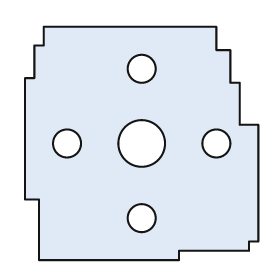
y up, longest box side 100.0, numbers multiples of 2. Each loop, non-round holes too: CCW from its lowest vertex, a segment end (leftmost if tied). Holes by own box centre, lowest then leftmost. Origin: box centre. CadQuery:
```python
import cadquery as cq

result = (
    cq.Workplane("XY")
    .moveTo(-44.0, -50.0)
    .lineTo(16.0, -50.0)
    .lineTo(16.0, -46.0)
    .lineTo(46.0, -46.0)
    .lineTo(46.0, -42.0)
    .lineTo(50.0, -42.0)
    .lineTo(50.0, 8.0)
    .lineTo(42.0, 8.0)
    .lineTo(42.0, 26.0)
    .lineTo(38.0, 26.0)
    .lineTo(38.0, 40.0)
    .lineTo(32.0, 40.0)
    .lineTo(32.0, 50.0)
    .lineTo(-42.0, 50.0)
    .lineTo(-42.0, 42.0)
    .lineTo(-46.0, 42.0)
    .lineTo(-46.0, 28.0)
    .lineTo(-50.0, 28.0)
    .lineTo(-50.0, -24.0)
    .lineTo(-44.0, -24.0)
    .close()
    .moveTo(0.0, -32.0)
    .circle(6.0)
    .moveTo(-32.0, 0.0)
    .circle(6.0)
    .moveTo(0.0, 0.0)
    .circle(10.0)
    .moveTo(32.0, 0.0)
    .circle(6.0)
    .moveTo(0.0, 32.0)
    .circle(6.0)
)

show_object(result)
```